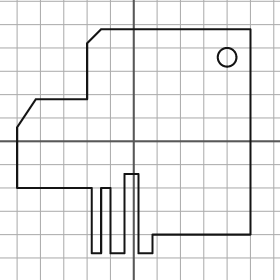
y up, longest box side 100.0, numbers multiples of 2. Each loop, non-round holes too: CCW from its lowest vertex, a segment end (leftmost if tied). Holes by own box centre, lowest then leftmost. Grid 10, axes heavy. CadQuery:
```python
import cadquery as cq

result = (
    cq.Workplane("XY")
    .moveTo(-18.0, -48.0)
    .lineTo(-14.0, -48.0)
    .lineTo(-14.0, -20.0)
    .lineTo(-10.0, -20.0)
    .lineTo(-10.0, -48.0)
    .lineTo(-4.0, -48.0)
    .lineTo(-4.0, -14.0)
    .lineTo(2.0, -14.0)
    .lineTo(2.0, -48.0)
    .lineTo(8.0, -48.0)
    .lineTo(8.0, -40.0)
    .lineTo(50.0, -40.0)
    .lineTo(50.0, 48.0)
    .lineTo(-14.0, 48.0)
    .lineTo(-20.0, 42.0)
    .lineTo(-20.0, 18.0)
    .lineTo(-42.0, 18.0)
    .lineTo(-50.0, 6.0)
    .lineTo(-50.0, -20.0)
    .lineTo(-18.0, -20.0)
    .close()
    .moveTo(40.0, 36.0)
    .circle(4.0)
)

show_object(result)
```